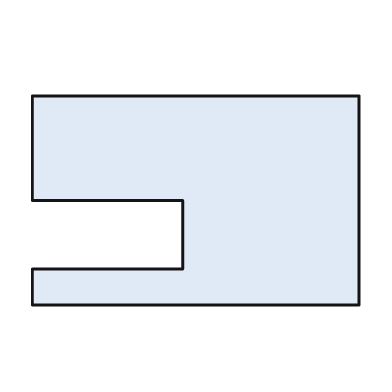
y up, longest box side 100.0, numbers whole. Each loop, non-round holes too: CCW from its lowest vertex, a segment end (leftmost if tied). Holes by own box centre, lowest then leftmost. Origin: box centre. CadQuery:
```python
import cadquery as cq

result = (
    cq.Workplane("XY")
    .moveTo(-50.0, -32.0)
    .lineTo(50.0, -32.0)
    .lineTo(50.0, 32.0)
    .lineTo(-50.0, 32.0)
    .lineTo(-50.0, 0.0)
    .lineTo(-4.0, 0.0)
    .lineTo(-4.0, -21.0)
    .lineTo(-50.0, -21.0)
    .close()
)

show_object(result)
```